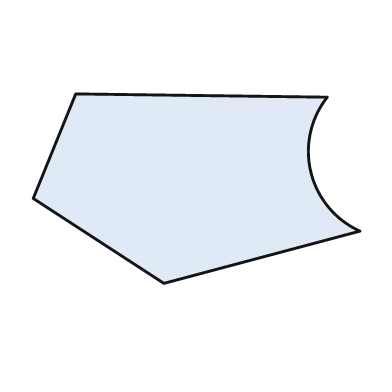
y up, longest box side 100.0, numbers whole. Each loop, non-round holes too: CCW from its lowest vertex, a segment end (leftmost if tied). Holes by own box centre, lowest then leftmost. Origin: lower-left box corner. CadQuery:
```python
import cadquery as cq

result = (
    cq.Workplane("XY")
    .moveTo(40.0, 0.0)
    .lineTo(100.0, 16.0)
    .threePointArc((85.0, 34.0), (90.0, 57.0))
    .lineTo(13.0, 58.0)
    .lineTo(0.0, 26.0)
    .close()
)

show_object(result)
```